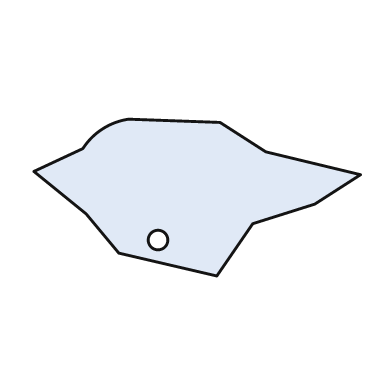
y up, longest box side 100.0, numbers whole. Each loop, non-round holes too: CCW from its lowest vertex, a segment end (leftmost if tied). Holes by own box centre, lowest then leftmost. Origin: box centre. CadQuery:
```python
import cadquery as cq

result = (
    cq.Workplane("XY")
    .moveTo(6.0, -24.0)
    .lineTo(17.0, -8.0)
    .lineTo(36.0, -2.0)
    .lineTo(50.0, 7.0)
    .lineTo(21.0, 14.0)
    .lineTo(7.0, 23.0)
    .lineTo(-21.0, 24.0)
    .threePointArc((-29.0, 21.0), (-35.0, 15.0))
    .lineTo(-50.0, 8.0)
    .lineTo(-34.0, -5.0)
    .lineTo(-24.0, -17.0)
    .close()
    .moveTo(-12.0, -13.0)
    .circle(3.0)
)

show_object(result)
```